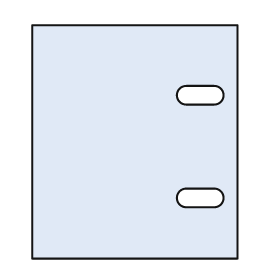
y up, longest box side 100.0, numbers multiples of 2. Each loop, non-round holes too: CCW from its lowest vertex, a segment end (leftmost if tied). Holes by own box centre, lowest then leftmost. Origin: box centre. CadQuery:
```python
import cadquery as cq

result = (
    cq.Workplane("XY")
    .moveTo(-44.0, -50.0)
    .lineTo(44.0, -50.0)
    .lineTo(44.0, 50.0)
    .lineTo(-44.0, 50.0)
    .close()
    .moveTo(22.0, -28.0)
    .lineTo(34.0, -28.0)
    .threePointArc((38.0, -24.0), (34.0, -20.0))
    .lineTo(22.0, -20.0)
    .threePointArc((18.0, -24.0), (22.0, -28.0))
    .close()
    .moveTo(22.0, 16.0)
    .lineTo(34.0, 16.0)
    .threePointArc((38.0, 20.0), (34.0, 24.0))
    .lineTo(22.0, 24.0)
    .threePointArc((18.0, 20.0), (22.0, 16.0))
    .close()
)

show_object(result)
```